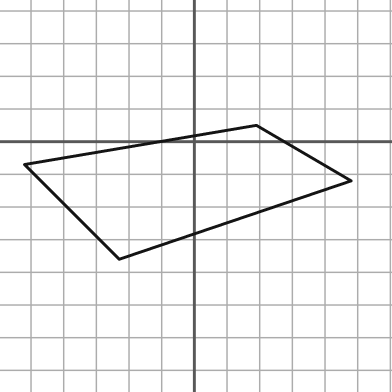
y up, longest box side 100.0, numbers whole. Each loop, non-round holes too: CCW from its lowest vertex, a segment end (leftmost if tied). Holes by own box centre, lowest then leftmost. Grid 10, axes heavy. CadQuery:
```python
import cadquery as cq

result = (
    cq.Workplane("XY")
    .moveTo(-23.0, -36.0)
    .lineTo(48.0, -12.0)
    .lineTo(19.0, 5.0)
    .lineTo(-52.0, -7.0)
    .close()
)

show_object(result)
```